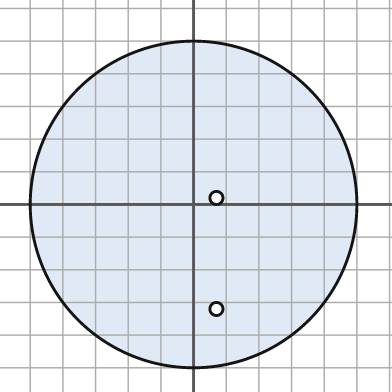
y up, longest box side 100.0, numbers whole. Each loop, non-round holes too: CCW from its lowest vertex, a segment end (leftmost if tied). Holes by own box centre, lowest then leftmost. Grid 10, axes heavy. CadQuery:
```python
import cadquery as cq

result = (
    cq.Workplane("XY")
    .moveTo(0.0, 0.0)
    .circle(50.0)
    .moveTo(7.0, -32.0)
    .circle(2.0)
    .moveTo(7.0, 2.0)
    .circle(2.0)
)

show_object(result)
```